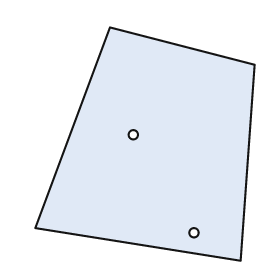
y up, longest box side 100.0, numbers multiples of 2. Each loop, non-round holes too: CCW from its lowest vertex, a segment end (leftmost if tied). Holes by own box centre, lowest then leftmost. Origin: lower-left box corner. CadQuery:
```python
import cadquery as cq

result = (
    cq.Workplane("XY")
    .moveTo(88.0, 0.0)
    .lineTo(94.0, 84.0)
    .lineTo(32.0, 100.0)
    .lineTo(0.0, 14.0)
    .close()
    .moveTo(68.0, 12.0)
    .circle(2.0)
    .moveTo(42.0, 54.0)
    .circle(2.0)
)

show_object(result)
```